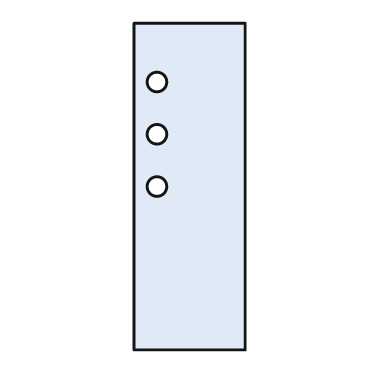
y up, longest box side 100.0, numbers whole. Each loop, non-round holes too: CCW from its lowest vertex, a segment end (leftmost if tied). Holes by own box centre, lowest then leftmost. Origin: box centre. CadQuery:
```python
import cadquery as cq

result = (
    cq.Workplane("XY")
    .moveTo(-17.0, -50.0)
    .lineTo(17.0, -50.0)
    .lineTo(17.0, 50.0)
    .lineTo(-17.0, 50.0)
    .close()
    .moveTo(-10.0, 0.0)
    .circle(3.0)
    .moveTo(-10.0, 16.0)
    .circle(3.0)
    .moveTo(-10.0, 32.0)
    .circle(3.0)
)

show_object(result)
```